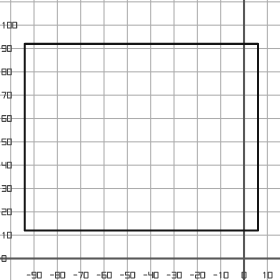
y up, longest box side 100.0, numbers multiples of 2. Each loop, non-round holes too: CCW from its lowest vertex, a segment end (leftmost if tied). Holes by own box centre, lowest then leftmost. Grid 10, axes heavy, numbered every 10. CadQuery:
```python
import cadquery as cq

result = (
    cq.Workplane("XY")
    .moveTo(-94.0, 12.0)
    .lineTo(6.0, 12.0)
    .lineTo(6.0, 92.0)
    .lineTo(-94.0, 92.0)
    .close()
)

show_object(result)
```